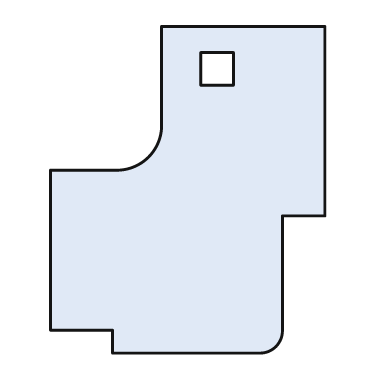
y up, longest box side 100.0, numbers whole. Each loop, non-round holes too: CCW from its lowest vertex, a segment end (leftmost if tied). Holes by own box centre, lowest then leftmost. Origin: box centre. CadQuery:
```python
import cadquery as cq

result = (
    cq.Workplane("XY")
    .moveTo(-23.0, -50.0)
    .lineTo(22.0, -50.0)
    .threePointArc((27.0, -48.0), (29.0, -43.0))
    .lineTo(29.0, -8.0)
    .lineTo(42.0, -8.0)
    .lineTo(42.0, 50.0)
    .lineTo(-8.0, 50.0)
    .lineTo(-8.0, 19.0)
    .threePointArc((-12.0, 10.0), (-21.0, 6.0))
    .lineTo(-42.0, 6.0)
    .lineTo(-42.0, -43.0)
    .lineTo(-23.0, -43.0)
    .close()
    .moveTo(4.0, 32.0)
    .lineTo(14.0, 32.0)
    .lineTo(14.0, 42.0)
    .lineTo(4.0, 42.0)
    .close()
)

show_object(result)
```